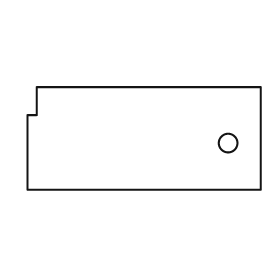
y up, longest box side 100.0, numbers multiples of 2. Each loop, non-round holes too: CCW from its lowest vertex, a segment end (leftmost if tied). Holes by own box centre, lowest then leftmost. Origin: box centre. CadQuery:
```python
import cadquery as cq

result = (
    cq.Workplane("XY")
    .moveTo(-50.0, -22.0)
    .lineTo(50.0, -22.0)
    .lineTo(50.0, 22.0)
    .lineTo(-46.0, 22.0)
    .lineTo(-46.0, 10.0)
    .lineTo(-50.0, 10.0)
    .close()
    .moveTo(36.0, -2.0)
    .circle(4.0)
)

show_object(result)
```